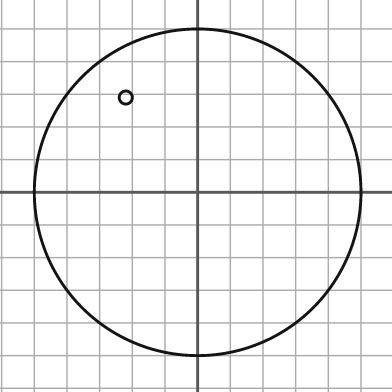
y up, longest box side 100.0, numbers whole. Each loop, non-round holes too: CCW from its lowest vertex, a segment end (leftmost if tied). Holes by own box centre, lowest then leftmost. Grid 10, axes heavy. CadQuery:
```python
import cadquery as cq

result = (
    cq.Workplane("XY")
    .moveTo(0.0, 0.0)
    .circle(50.0)
    .moveTo(-22.0, 29.0)
    .circle(2.0)
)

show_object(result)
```